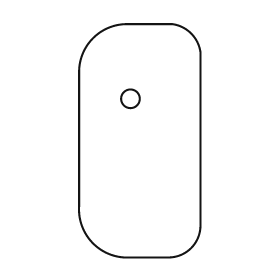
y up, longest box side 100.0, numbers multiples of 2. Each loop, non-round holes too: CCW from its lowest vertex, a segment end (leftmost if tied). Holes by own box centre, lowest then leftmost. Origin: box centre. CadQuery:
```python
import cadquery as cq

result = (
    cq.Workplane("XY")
    .moveTo(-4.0, -50.0)
    .lineTo(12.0, -50.0)
    .threePointArc((22.0, -46.0), (26.0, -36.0))
    .lineTo(26.0, 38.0)
    .threePointArc((22.0, 46.0), (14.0, 50.0))
    .lineTo(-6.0, 50.0)
    .threePointArc((-20.0, 44.0), (-26.0, 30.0))
    .lineTo(-26.0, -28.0)
    .threePointArc((-20.0, -44.0), (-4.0, -50.0))
    .close()
    .moveTo(-4.0, 18.0)
    .circle(4.0)
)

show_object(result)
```